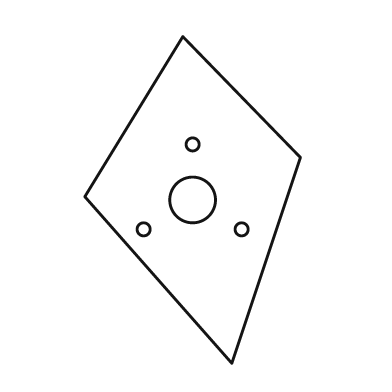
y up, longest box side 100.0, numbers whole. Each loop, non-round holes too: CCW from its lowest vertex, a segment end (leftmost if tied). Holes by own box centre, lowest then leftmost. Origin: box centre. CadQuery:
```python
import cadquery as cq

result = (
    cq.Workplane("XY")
    .moveTo(12.0, -50.0)
    .lineTo(33.0, 13.0)
    .lineTo(-3.0, 50.0)
    .lineTo(-33.0, 1.0)
    .close()
    .moveTo(-15.0, -9.0)
    .circle(2.0)
    .moveTo(15.0, -9.0)
    .circle(2.0)
    .moveTo(0.0, 0.0)
    .circle(7.0)
    .moveTo(0.0, 17.0)
    .circle(2.0)
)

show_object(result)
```